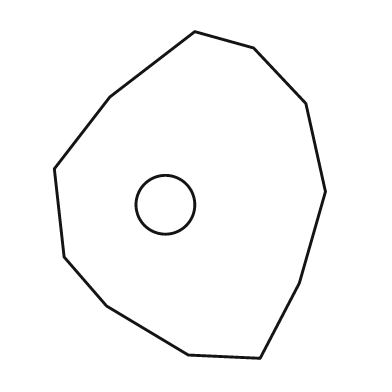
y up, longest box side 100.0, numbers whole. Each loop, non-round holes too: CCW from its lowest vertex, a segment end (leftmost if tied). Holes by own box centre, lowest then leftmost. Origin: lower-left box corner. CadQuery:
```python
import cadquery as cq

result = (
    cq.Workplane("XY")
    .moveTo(63.0, 0.0)
    .lineTo(75.0, 23.0)
    .lineTo(83.0, 51.0)
    .lineTo(77.0, 78.0)
    .lineTo(61.0, 95.0)
    .lineTo(43.0, 100.0)
    .lineTo(17.0, 80.0)
    .lineTo(0.0, 58.0)
    .lineTo(3.0, 31.0)
    .lineTo(16.0, 16.0)
    .lineTo(41.0, 1.0)
    .close()
    .moveTo(34.0, 47.0)
    .circle(9.0)
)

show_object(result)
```